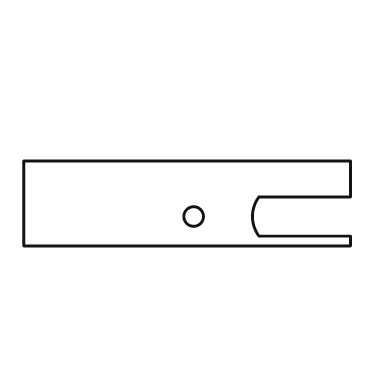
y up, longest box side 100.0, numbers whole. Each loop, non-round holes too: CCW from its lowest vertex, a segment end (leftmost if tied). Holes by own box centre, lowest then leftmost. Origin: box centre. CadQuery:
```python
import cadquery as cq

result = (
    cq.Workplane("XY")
    .moveTo(-50.0, -13.0)
    .lineTo(50.0, -13.0)
    .lineTo(50.0, -10.0)
    .lineTo(22.0, -10.0)
    .threePointArc((20.0, -4.0), (22.0, 2.0))
    .lineTo(50.0, 2.0)
    .lineTo(50.0, 13.0)
    .lineTo(-50.0, 13.0)
    .close()
    .moveTo(2.0, -4.0)
    .circle(3.0)
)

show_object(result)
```